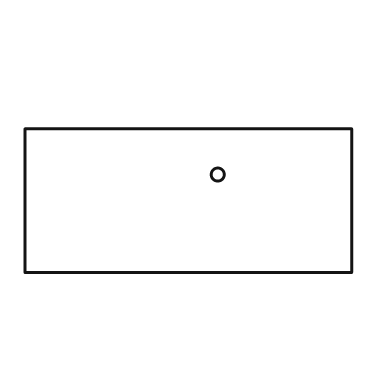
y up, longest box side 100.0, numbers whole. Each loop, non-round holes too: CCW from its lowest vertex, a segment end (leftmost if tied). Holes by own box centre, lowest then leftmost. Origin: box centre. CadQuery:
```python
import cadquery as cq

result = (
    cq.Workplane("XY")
    .moveTo(-50.0, -22.0)
    .lineTo(50.0, -22.0)
    .lineTo(50.0, 22.0)
    .lineTo(-50.0, 22.0)
    .close()
    .moveTo(9.0, 8.0)
    .circle(2.0)
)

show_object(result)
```